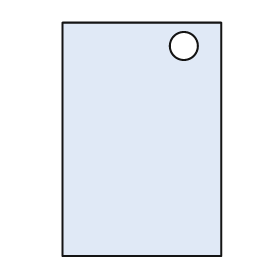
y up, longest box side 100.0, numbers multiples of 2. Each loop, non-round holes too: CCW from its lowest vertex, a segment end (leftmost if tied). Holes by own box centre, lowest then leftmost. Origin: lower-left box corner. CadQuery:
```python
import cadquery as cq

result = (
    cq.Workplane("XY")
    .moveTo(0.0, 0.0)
    .lineTo(68.0, 0.0)
    .lineTo(68.0, 100.0)
    .lineTo(0.0, 100.0)
    .close()
    .moveTo(52.0, 90.0)
    .circle(6.0)
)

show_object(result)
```